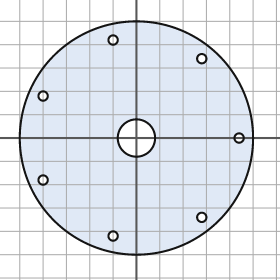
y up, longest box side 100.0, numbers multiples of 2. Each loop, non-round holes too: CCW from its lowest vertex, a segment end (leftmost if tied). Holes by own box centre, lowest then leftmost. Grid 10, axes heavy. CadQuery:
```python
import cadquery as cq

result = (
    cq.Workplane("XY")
    .moveTo(0.0, 0.0)
    .circle(50.0)
    .moveTo(-10.0, -42.0)
    .circle(2.0)
    .moveTo(28.0, -34.0)
    .circle(2.0)
    .moveTo(-40.0, -18.0)
    .circle(2.0)
    .moveTo(0.0, 0.0)
    .circle(8.0)
    .moveTo(44.0, 0.0)
    .circle(2.0)
    .moveTo(-40.0, 18.0)
    .circle(2.0)
    .moveTo(28.0, 34.0)
    .circle(2.0)
    .moveTo(-10.0, 42.0)
    .circle(2.0)
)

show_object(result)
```